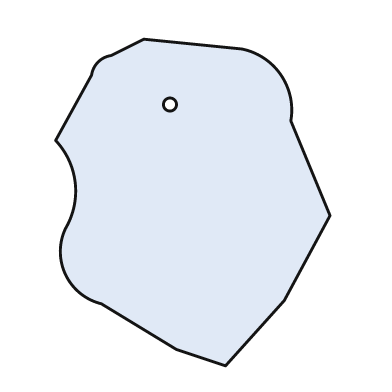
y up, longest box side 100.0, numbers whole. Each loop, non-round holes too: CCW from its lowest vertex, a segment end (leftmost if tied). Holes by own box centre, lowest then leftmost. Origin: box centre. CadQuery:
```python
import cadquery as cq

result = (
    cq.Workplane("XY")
    .moveTo(10.0, -50.0)
    .lineTo(28.0, -30.0)
    .lineTo(42.0, -4.0)
    .lineTo(30.0, 25.0)
    .threePointArc((27.0, 39.0), (15.0, 47.0))
    .lineTo(-15.0, 50.0)
    .lineTo(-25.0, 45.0)
    .threePointArc((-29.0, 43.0), (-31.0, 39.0))
    .lineTo(-42.0, 19.0)
    .threePointArc((-36.0, 6.0), (-39.0, -8.0))
    .threePointArc((-39.0, -22.0), (-28.0, -31.0))
    .lineTo(-5.0, -45.0)
    .close()
    .moveTo(-7.0, 30.0)
    .circle(2.0)
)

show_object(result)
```